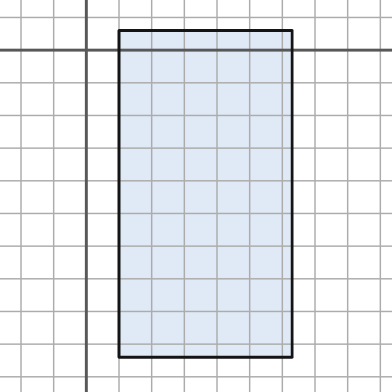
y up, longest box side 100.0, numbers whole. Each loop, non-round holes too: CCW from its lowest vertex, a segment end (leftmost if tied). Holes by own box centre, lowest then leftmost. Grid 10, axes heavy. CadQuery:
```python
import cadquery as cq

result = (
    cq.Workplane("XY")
    .moveTo(10.0, -94.0)
    .lineTo(63.0, -94.0)
    .lineTo(63.0, 6.0)
    .lineTo(10.0, 6.0)
    .close()
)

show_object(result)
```